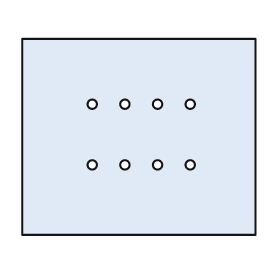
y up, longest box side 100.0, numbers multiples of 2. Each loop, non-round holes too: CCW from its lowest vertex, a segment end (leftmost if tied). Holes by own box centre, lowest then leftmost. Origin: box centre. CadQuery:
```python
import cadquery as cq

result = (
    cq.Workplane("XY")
    .moveTo(-50.0, -42.0)
    .lineTo(50.0, -42.0)
    .lineTo(50.0, 42.0)
    .lineTo(-50.0, 42.0)
    .close()
    .moveTo(-20.0, -12.0)
    .circle(2.0)
    .moveTo(-6.0, -12.0)
    .circle(2.0)
    .moveTo(8.0, -12.0)
    .circle(2.0)
    .moveTo(22.0, -12.0)
    .circle(2.0)
    .moveTo(-20.0, 14.0)
    .circle(2.0)
    .moveTo(-6.0, 14.0)
    .circle(2.0)
    .moveTo(8.0, 14.0)
    .circle(2.0)
    .moveTo(22.0, 14.0)
    .circle(2.0)
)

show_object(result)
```